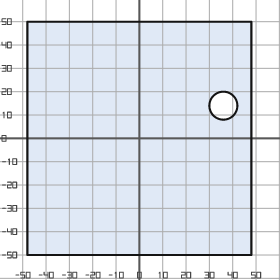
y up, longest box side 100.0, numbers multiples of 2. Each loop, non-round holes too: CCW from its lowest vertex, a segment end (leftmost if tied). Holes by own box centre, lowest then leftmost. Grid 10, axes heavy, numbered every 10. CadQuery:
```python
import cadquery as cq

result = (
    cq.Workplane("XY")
    .moveTo(-48.0, -50.0)
    .lineTo(48.0, -50.0)
    .lineTo(48.0, 50.0)
    .lineTo(-48.0, 50.0)
    .close()
    .moveTo(36.0, 14.0)
    .circle(6.0)
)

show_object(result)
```